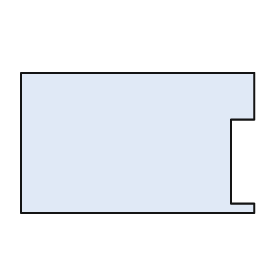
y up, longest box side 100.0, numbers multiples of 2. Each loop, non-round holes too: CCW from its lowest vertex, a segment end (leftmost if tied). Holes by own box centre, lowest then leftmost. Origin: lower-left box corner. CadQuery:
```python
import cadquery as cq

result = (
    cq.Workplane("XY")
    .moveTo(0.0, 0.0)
    .lineTo(100.0, 0.0)
    .lineTo(100.0, 4.0)
    .lineTo(90.0, 4.0)
    .lineTo(90.0, 40.0)
    .lineTo(100.0, 40.0)
    .lineTo(100.0, 60.0)
    .lineTo(0.0, 60.0)
    .close()
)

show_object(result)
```